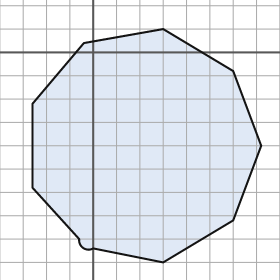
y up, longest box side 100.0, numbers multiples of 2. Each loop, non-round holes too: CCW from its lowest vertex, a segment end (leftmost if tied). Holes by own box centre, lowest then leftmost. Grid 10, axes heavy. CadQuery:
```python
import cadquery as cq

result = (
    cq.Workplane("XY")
    .moveTo(30.0, -90.0)
    .lineTo(60.0, -72.0)
    .lineTo(72.0, -40.0)
    .lineTo(60.0, -8.0)
    .lineTo(30.0, 10.0)
    .lineTo(-4.0, 4.0)
    .lineTo(-26.0, -22.0)
    .lineTo(-26.0, -58.0)
    .lineTo(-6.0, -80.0)
    .threePointArc((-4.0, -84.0), (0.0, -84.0))
    .close()
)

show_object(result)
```